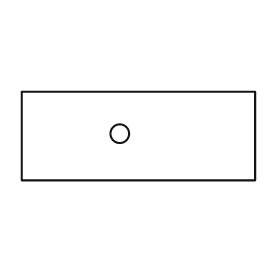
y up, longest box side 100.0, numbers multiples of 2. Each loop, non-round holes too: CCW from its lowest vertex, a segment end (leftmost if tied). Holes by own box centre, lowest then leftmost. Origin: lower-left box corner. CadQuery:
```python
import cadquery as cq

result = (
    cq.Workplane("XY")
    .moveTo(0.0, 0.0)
    .lineTo(100.0, 0.0)
    .lineTo(100.0, 38.0)
    .lineTo(0.0, 38.0)
    .close()
    .moveTo(42.0, 20.0)
    .circle(4.0)
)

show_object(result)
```